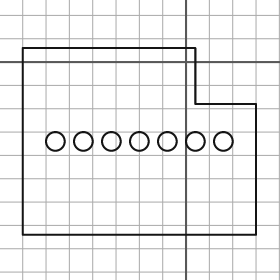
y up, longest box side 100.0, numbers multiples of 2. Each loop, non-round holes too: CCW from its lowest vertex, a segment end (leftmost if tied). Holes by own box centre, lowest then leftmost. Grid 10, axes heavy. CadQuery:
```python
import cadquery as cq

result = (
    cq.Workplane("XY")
    .moveTo(-70.0, -74.0)
    .lineTo(30.0, -74.0)
    .lineTo(30.0, -18.0)
    .lineTo(4.0, -18.0)
    .lineTo(4.0, 6.0)
    .lineTo(-70.0, 6.0)
    .close()
    .moveTo(-56.0, -34.0)
    .circle(4.0)
    .moveTo(-44.0, -34.0)
    .circle(4.0)
    .moveTo(-32.0, -34.0)
    .circle(4.0)
    .moveTo(-20.0, -34.0)
    .circle(4.0)
    .moveTo(-8.0, -34.0)
    .circle(4.0)
    .moveTo(4.0, -34.0)
    .circle(4.0)
    .moveTo(16.0, -34.0)
    .circle(4.0)
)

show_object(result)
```